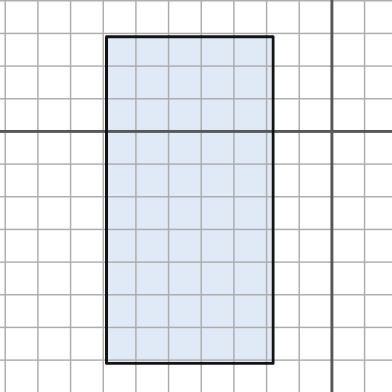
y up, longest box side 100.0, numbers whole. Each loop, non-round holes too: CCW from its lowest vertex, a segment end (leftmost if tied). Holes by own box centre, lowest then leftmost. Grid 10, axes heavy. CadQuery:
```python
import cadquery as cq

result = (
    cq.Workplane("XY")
    .moveTo(-69.0, -71.0)
    .lineTo(-18.0, -71.0)
    .lineTo(-18.0, 29.0)
    .lineTo(-69.0, 29.0)
    .close()
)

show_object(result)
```